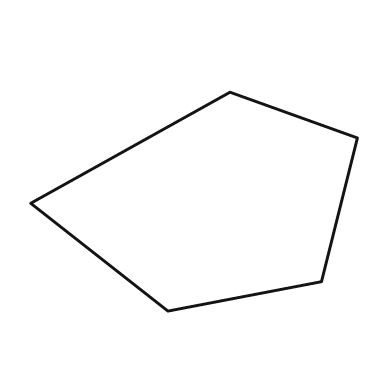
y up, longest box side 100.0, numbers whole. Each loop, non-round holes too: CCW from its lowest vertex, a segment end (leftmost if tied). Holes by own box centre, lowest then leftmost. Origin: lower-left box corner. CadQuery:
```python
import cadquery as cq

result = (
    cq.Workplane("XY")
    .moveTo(42.0, 0.0)
    .lineTo(89.0, 9.0)
    .lineTo(100.0, 53.0)
    .lineTo(61.0, 67.0)
    .lineTo(0.0, 33.0)
    .close()
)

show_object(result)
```